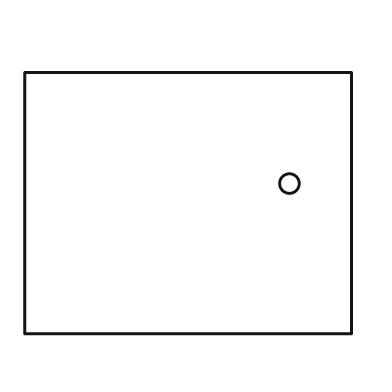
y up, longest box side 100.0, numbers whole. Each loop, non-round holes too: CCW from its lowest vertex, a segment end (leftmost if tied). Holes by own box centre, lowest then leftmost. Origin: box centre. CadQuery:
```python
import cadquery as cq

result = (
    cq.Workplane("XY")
    .moveTo(-50.0, -40.0)
    .lineTo(50.0, -40.0)
    .lineTo(50.0, 40.0)
    .lineTo(-50.0, 40.0)
    .close()
    .moveTo(31.0, 6.0)
    .circle(3.0)
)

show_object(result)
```